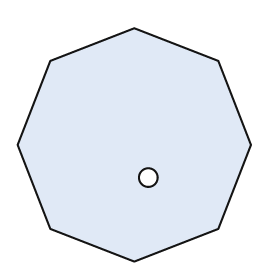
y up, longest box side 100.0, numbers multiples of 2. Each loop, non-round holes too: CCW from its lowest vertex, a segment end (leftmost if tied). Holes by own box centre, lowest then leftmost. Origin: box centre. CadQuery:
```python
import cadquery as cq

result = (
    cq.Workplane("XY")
    .moveTo(0.0, -50.0)
    .lineTo(36.0, -36.0)
    .lineTo(50.0, 0.0)
    .lineTo(36.0, 36.0)
    .lineTo(0.0, 50.0)
    .lineTo(-36.0, 36.0)
    .lineTo(-50.0, 0.0)
    .lineTo(-36.0, -36.0)
    .close()
    .moveTo(6.0, -14.0)
    .circle(4.0)
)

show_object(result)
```